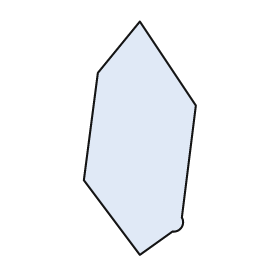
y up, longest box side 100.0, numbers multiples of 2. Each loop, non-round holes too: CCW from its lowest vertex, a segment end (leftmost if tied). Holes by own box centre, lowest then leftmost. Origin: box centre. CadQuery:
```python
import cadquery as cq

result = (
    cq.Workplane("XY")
    .moveTo(0.0, -50.0)
    .lineTo(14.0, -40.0)
    .threePointArc((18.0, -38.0), (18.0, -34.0))
    .lineTo(24.0, 14.0)
    .lineTo(0.0, 50.0)
    .lineTo(-18.0, 28.0)
    .lineTo(-24.0, -18.0)
    .close()
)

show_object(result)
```